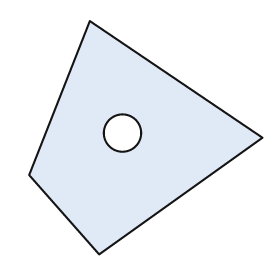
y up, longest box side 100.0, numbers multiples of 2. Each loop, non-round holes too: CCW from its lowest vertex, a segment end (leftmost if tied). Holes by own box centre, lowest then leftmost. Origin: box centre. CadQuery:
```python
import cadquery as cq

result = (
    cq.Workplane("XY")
    .moveTo(-20.0, -50.0)
    .lineTo(50.0, 0.0)
    .lineTo(-24.0, 50.0)
    .lineTo(-50.0, -16.0)
    .close()
    .moveTo(-10.0, 2.0)
    .circle(8.0)
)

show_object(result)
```